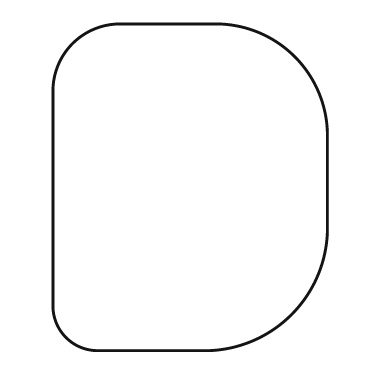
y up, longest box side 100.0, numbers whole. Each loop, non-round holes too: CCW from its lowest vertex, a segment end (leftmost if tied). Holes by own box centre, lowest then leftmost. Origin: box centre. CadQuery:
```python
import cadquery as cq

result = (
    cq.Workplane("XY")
    .moveTo(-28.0, -50.0)
    .lineTo(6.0, -50.0)
    .threePointArc((31.0, -39.0), (42.0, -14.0))
    .lineTo(42.0, 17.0)
    .threePointArc((32.0, 40.0), (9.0, 50.0))
    .lineTo(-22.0, 50.0)
    .threePointArc((-36.0, 44.0), (-42.0, 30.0))
    .lineTo(-42.0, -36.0)
    .threePointArc((-38.0, -46.0), (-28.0, -50.0))
    .close()
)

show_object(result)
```